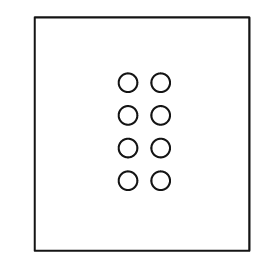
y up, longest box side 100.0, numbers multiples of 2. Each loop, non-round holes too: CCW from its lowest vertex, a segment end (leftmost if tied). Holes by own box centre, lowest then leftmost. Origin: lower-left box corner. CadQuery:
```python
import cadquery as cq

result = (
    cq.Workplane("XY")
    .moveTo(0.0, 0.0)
    .lineTo(92.0, 0.0)
    .lineTo(92.0, 100.0)
    .lineTo(0.0, 100.0)
    .close()
    .moveTo(40.0, 30.0)
    .circle(4.0)
    .moveTo(54.0, 30.0)
    .circle(4.0)
    .moveTo(40.0, 44.0)
    .circle(4.0)
    .moveTo(54.0, 44.0)
    .circle(4.0)
    .moveTo(40.0, 58.0)
    .circle(4.0)
    .moveTo(54.0, 58.0)
    .circle(4.0)
    .moveTo(40.0, 72.0)
    .circle(4.0)
    .moveTo(54.0, 72.0)
    .circle(4.0)
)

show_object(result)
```